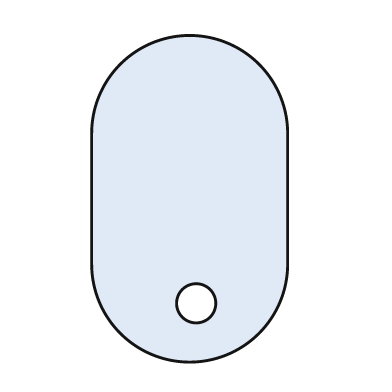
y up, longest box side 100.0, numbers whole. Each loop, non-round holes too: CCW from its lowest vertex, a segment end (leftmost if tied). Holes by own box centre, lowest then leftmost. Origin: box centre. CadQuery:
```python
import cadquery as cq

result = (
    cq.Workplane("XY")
    .moveTo(-30.0, -20.0)
    .threePointArc((0.0, -50.0), (30.0, -20.0))
    .lineTo(30.0, 20.0)
    .threePointArc((0.0, 50.0), (-30.0, 20.0))
    .close()
    .moveTo(2.0, -32.0)
    .circle(6.0)
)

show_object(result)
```